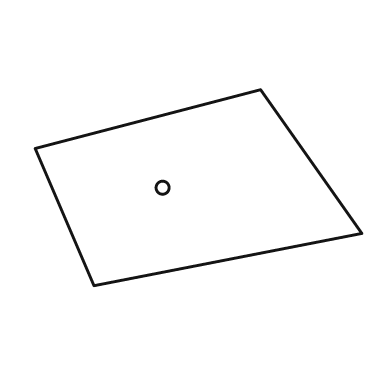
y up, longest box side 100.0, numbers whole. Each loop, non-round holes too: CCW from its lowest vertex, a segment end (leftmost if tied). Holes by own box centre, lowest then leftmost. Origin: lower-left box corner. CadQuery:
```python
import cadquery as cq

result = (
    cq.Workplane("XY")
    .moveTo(18.0, 0.0)
    .lineTo(100.0, 16.0)
    .lineTo(69.0, 60.0)
    .lineTo(0.0, 42.0)
    .close()
    .moveTo(39.0, 30.0)
    .circle(2.0)
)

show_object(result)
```